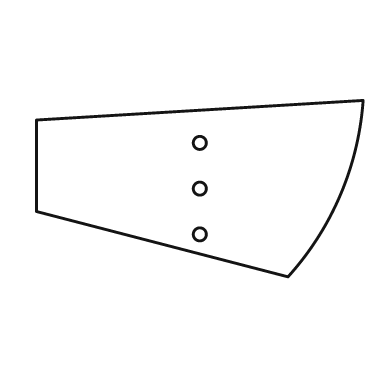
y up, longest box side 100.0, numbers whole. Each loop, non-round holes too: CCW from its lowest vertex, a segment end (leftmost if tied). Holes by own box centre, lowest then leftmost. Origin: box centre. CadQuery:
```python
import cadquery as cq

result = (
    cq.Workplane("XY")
    .moveTo(27.0, -27.0)
    .threePointArc((43.0, -2.0), (50.0, 27.0))
    .lineTo(-50.0, 21.0)
    .lineTo(-50.0, -7.0)
    .close()
    .moveTo(0.0, -14.0)
    .circle(2.0)
    .moveTo(0.0, 0.0)
    .circle(2.0)
    .moveTo(0.0, 14.0)
    .circle(2.0)
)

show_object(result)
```